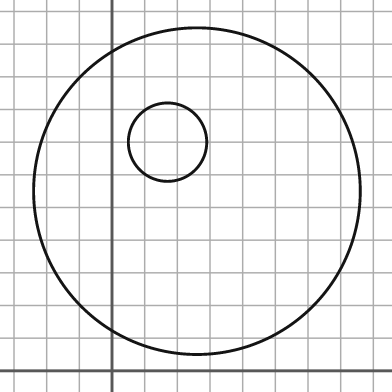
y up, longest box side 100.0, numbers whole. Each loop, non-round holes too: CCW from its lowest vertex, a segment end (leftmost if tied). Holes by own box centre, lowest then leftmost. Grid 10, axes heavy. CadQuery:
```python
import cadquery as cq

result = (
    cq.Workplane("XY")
    .moveTo(26.0, 55.0)
    .circle(50.0)
    .moveTo(17.0, 70.0)
    .circle(12.0)
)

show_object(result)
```